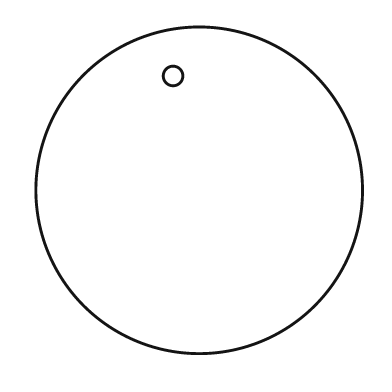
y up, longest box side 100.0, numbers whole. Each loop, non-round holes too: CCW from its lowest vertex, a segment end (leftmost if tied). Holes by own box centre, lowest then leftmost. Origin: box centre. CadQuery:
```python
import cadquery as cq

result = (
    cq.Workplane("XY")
    .moveTo(0.0, 0.0)
    .circle(50.0)
    .moveTo(-8.0, 35.0)
    .circle(3.0)
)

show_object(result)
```